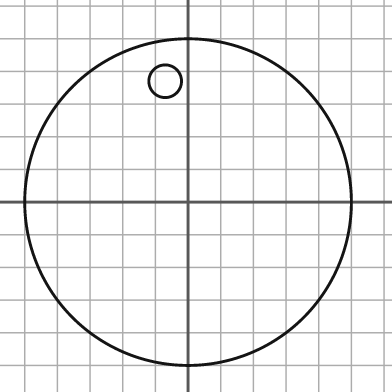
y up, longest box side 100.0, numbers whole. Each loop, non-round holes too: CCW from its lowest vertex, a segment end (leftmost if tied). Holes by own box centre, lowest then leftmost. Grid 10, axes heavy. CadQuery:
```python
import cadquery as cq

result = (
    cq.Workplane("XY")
    .moveTo(0.0, 0.0)
    .circle(50.0)
    .moveTo(-7.0, 37.0)
    .circle(5.0)
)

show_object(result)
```